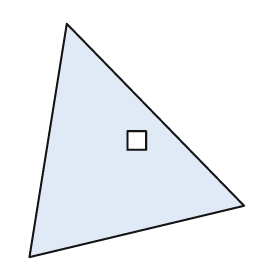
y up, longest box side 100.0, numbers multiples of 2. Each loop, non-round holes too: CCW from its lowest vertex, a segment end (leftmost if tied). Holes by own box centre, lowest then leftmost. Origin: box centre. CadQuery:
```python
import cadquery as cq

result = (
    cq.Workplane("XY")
    .moveTo(-46.0, -50.0)
    .lineTo(46.0, -28.0)
    .lineTo(-30.0, 50.0)
    .close()
    .moveTo(-4.0, -4.0)
    .lineTo(4.0, -4.0)
    .lineTo(4.0, 4.0)
    .lineTo(-4.0, 4.0)
    .close()
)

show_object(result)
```